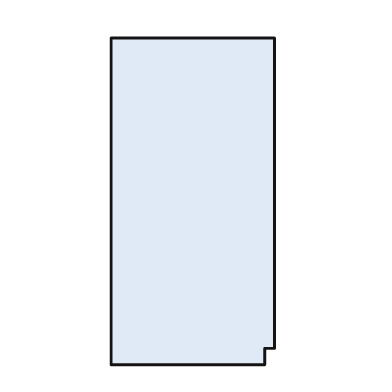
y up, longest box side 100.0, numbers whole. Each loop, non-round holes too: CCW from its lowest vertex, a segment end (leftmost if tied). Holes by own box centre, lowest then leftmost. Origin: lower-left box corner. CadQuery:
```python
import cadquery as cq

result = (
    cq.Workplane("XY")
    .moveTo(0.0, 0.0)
    .lineTo(47.0, 0.0)
    .lineTo(47.0, 5.0)
    .lineTo(50.0, 5.0)
    .lineTo(50.0, 100.0)
    .lineTo(0.0, 100.0)
    .close()
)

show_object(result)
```